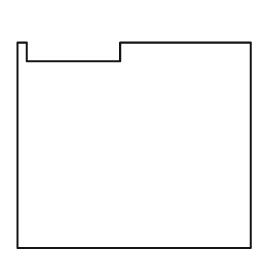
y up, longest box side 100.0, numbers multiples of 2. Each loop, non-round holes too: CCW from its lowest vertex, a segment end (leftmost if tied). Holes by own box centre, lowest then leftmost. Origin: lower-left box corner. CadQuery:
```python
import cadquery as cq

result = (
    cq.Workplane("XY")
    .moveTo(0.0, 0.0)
    .lineTo(100.0, 0.0)
    .lineTo(100.0, 88.0)
    .lineTo(44.0, 88.0)
    .lineTo(44.0, 80.0)
    .lineTo(4.0, 80.0)
    .lineTo(4.0, 88.0)
    .lineTo(0.0, 88.0)
    .close()
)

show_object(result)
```